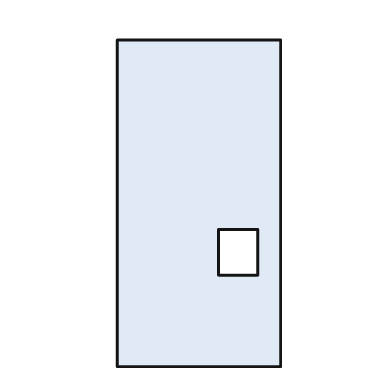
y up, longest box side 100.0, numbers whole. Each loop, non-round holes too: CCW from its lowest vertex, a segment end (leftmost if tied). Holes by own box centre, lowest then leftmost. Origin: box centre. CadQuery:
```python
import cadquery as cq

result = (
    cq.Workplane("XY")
    .moveTo(-25.0, -50.0)
    .lineTo(25.0, -50.0)
    .lineTo(25.0, 50.0)
    .lineTo(-25.0, 50.0)
    .close()
    .moveTo(6.0, -22.0)
    .lineTo(18.0, -22.0)
    .lineTo(18.0, -8.0)
    .lineTo(6.0, -8.0)
    .close()
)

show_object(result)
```